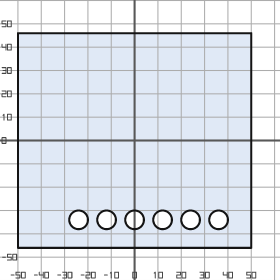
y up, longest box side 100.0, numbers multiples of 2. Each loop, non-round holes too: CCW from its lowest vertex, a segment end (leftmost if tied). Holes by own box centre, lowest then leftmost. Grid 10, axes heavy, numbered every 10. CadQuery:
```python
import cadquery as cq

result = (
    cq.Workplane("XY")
    .moveTo(-50.0, -46.0)
    .lineTo(50.0, -46.0)
    .lineTo(50.0, 46.0)
    .lineTo(-50.0, 46.0)
    .close()
    .moveTo(-24.0, -34.0)
    .circle(4.0)
    .moveTo(-12.0, -34.0)
    .circle(4.0)
    .moveTo(0.0, -34.0)
    .circle(4.0)
    .moveTo(12.0, -34.0)
    .circle(4.0)
    .moveTo(24.0, -34.0)
    .circle(4.0)
    .moveTo(36.0, -34.0)
    .circle(4.0)
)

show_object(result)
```